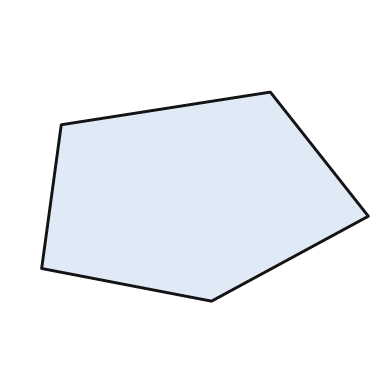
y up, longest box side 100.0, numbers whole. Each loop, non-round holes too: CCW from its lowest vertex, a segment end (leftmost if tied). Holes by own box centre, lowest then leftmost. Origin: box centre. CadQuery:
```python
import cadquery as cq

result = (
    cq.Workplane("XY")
    .moveTo(2.0, -32.0)
    .lineTo(50.0, -6.0)
    .lineTo(20.0, 32.0)
    .lineTo(-44.0, 22.0)
    .lineTo(-50.0, -22.0)
    .close()
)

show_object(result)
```